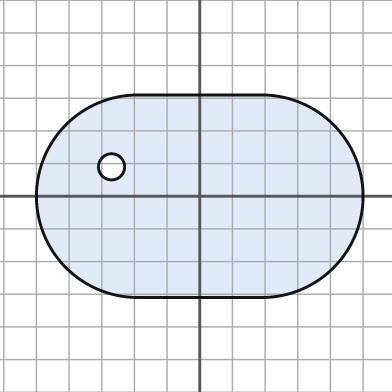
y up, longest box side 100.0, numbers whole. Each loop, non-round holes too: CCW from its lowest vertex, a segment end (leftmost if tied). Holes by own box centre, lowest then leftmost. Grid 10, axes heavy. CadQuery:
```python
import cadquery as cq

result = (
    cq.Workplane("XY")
    .moveTo(-19.0, -31.0)
    .lineTo(19.0, -31.0)
    .threePointArc((50.0, 0.0), (19.0, 31.0))
    .lineTo(-19.0, 31.0)
    .threePointArc((-50.0, 0.0), (-19.0, -31.0))
    .close()
    .moveTo(-27.0, 9.0)
    .circle(4.0)
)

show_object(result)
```